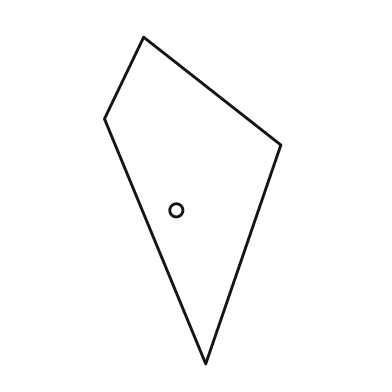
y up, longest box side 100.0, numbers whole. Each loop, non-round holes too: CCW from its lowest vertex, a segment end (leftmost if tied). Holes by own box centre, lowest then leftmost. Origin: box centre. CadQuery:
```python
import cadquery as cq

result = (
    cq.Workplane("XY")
    .moveTo(4.0, -50.0)
    .lineTo(27.0, 17.0)
    .lineTo(-15.0, 50.0)
    .lineTo(-27.0, 25.0)
    .close()
    .moveTo(-5.0, -3.0)
    .circle(2.0)
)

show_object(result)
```